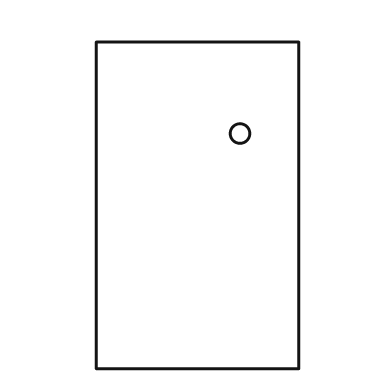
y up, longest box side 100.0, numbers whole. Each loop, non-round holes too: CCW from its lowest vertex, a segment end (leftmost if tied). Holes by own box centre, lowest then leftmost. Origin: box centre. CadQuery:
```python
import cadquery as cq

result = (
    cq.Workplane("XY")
    .moveTo(-31.0, -50.0)
    .lineTo(31.0, -50.0)
    .lineTo(31.0, 50.0)
    .lineTo(-31.0, 50.0)
    .close()
    .moveTo(13.0, 22.0)
    .circle(3.0)
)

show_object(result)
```